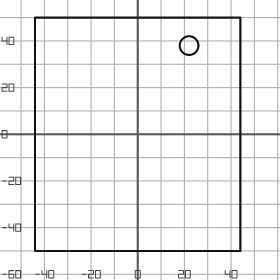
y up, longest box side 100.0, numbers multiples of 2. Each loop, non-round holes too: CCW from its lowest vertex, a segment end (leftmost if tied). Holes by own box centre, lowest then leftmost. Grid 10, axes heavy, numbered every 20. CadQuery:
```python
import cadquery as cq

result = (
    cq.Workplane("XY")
    .moveTo(-44.0, -50.0)
    .lineTo(44.0, -50.0)
    .lineTo(44.0, 50.0)
    .lineTo(-44.0, 50.0)
    .close()
    .moveTo(22.0, 38.0)
    .circle(4.0)
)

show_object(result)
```